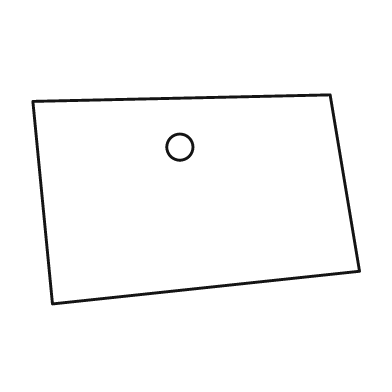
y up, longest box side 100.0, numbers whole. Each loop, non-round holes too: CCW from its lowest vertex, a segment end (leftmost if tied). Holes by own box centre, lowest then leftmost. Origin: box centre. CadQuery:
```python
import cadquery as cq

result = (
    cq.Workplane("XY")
    .moveTo(-44.0, -32.0)
    .lineTo(50.0, -22.0)
    .lineTo(41.0, 32.0)
    .lineTo(-50.0, 30.0)
    .close()
    .moveTo(-5.0, 16.0)
    .circle(4.0)
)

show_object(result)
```